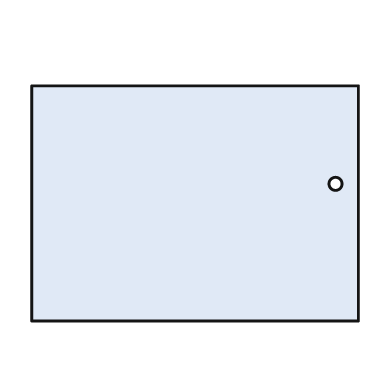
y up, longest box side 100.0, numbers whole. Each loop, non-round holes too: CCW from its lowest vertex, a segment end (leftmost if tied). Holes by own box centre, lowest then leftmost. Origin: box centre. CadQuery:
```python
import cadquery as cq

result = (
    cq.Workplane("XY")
    .moveTo(-50.0, -36.0)
    .lineTo(50.0, -36.0)
    .lineTo(50.0, 36.0)
    .lineTo(-50.0, 36.0)
    .close()
    .moveTo(43.0, 6.0)
    .circle(2.0)
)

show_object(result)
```